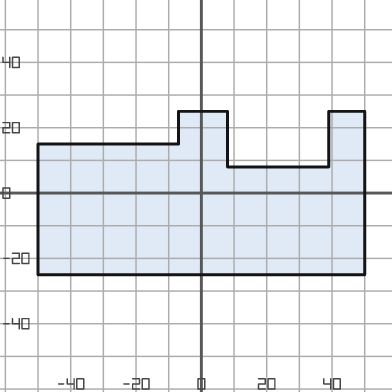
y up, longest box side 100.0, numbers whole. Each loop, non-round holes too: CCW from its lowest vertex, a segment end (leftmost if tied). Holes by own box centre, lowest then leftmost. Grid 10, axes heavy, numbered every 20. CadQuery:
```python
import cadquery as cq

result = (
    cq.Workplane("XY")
    .moveTo(-50.0, -25.0)
    .lineTo(50.0, -25.0)
    .lineTo(50.0, 25.0)
    .lineTo(39.0, 25.0)
    .lineTo(39.0, 8.0)
    .lineTo(8.0, 8.0)
    .lineTo(8.0, 25.0)
    .lineTo(-7.0, 25.0)
    .lineTo(-7.0, 15.0)
    .lineTo(-50.0, 15.0)
    .close()
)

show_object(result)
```